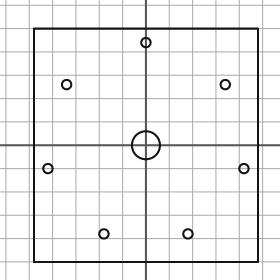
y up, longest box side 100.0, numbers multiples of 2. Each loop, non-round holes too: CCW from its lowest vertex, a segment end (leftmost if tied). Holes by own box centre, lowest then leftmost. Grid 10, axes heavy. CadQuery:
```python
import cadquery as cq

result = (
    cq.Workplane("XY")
    .moveTo(-48.0, -50.0)
    .lineTo(48.0, -50.0)
    .lineTo(48.0, 50.0)
    .lineTo(-48.0, 50.0)
    .close()
    .moveTo(-18.0, -38.0)
    .circle(2.0)
    .moveTo(18.0, -38.0)
    .circle(2.0)
    .moveTo(-42.0, -10.0)
    .circle(2.0)
    .moveTo(42.0, -10.0)
    .circle(2.0)
    .moveTo(0.0, 0.0)
    .circle(6.0)
    .moveTo(-34.0, 26.0)
    .circle(2.0)
    .moveTo(34.0, 26.0)
    .circle(2.0)
    .moveTo(0.0, 44.0)
    .circle(2.0)
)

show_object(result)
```